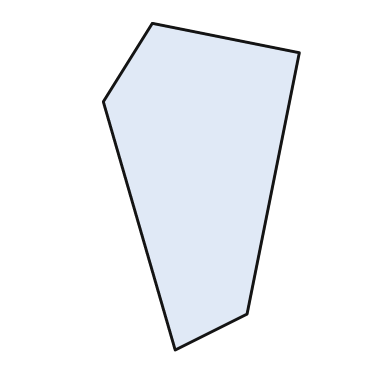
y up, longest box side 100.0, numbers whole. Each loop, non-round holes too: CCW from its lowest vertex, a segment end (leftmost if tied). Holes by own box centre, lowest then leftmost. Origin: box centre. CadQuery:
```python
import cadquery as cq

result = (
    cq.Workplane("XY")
    .moveTo(-8.0, -50.0)
    .lineTo(14.0, -39.0)
    .lineTo(30.0, 41.0)
    .lineTo(-15.0, 50.0)
    .lineTo(-30.0, 26.0)
    .close()
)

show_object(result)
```